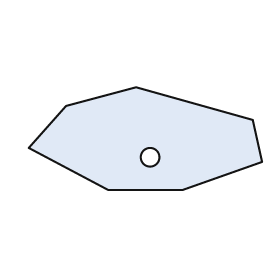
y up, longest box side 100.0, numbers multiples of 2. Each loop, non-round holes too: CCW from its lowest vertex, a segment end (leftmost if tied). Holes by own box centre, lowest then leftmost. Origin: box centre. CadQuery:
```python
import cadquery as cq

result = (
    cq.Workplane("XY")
    .moveTo(-16.0, -22.0)
    .lineTo(16.0, -22.0)
    .lineTo(50.0, -10.0)
    .lineTo(46.0, 8.0)
    .lineTo(-4.0, 22.0)
    .lineTo(-34.0, 14.0)
    .lineTo(-50.0, -4.0)
    .close()
    .moveTo(2.0, -8.0)
    .circle(4.0)
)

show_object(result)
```